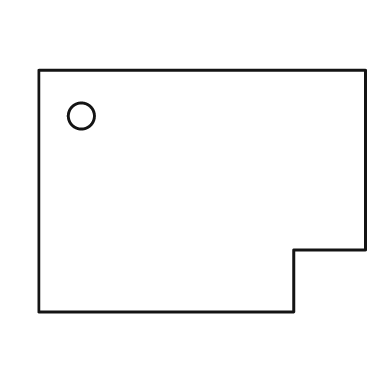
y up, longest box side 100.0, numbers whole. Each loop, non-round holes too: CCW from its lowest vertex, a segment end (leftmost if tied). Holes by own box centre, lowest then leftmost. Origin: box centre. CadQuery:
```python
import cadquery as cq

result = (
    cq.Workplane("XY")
    .moveTo(-50.0, -37.0)
    .lineTo(28.0, -37.0)
    .lineTo(28.0, -18.0)
    .lineTo(50.0, -18.0)
    .lineTo(50.0, 37.0)
    .lineTo(-50.0, 37.0)
    .close()
    .moveTo(-37.0, 23.0)
    .circle(4.0)
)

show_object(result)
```